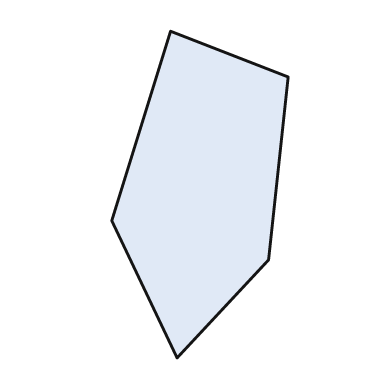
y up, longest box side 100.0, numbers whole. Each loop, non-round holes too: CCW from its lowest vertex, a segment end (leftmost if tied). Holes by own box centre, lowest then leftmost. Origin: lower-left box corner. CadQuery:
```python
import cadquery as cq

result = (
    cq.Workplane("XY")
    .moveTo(20.0, 0.0)
    .lineTo(48.0, 30.0)
    .lineTo(54.0, 86.0)
    .lineTo(18.0, 100.0)
    .lineTo(0.0, 42.0)
    .close()
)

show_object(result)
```